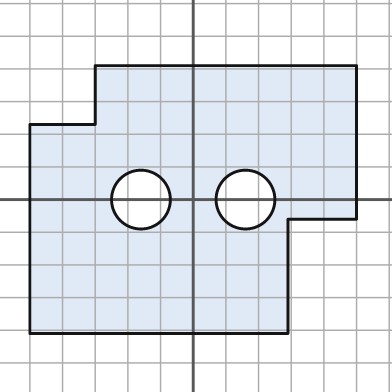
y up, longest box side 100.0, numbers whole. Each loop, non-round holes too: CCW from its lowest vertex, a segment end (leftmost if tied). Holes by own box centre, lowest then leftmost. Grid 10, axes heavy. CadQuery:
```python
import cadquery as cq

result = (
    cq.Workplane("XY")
    .moveTo(-50.0, -41.0)
    .lineTo(29.0, -41.0)
    .lineTo(29.0, -6.0)
    .lineTo(50.0, -6.0)
    .lineTo(50.0, 41.0)
    .lineTo(-30.0, 41.0)
    .lineTo(-30.0, 23.0)
    .lineTo(-50.0, 23.0)
    .close()
    .moveTo(-16.0, 0.0)
    .circle(9.0)
    .moveTo(16.0, 0.0)
    .circle(9.0)
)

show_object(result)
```